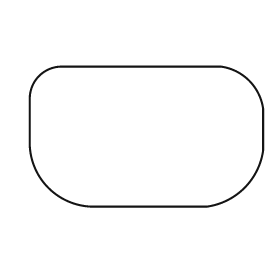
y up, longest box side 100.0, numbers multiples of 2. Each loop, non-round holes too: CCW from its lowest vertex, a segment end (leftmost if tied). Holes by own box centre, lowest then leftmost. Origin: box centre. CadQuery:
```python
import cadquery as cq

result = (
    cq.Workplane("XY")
    .moveTo(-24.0, -30.0)
    .lineTo(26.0, -30.0)
    .threePointArc((42.0, -22.0), (50.0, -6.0))
    .lineTo(50.0, 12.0)
    .threePointArc((44.0, 24.0), (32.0, 30.0))
    .lineTo(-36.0, 30.0)
    .threePointArc((-46.0, 26.0), (-50.0, 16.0))
    .lineTo(-50.0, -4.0)
    .threePointArc((-42.0, -22.0), (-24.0, -30.0))
    .close()
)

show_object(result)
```